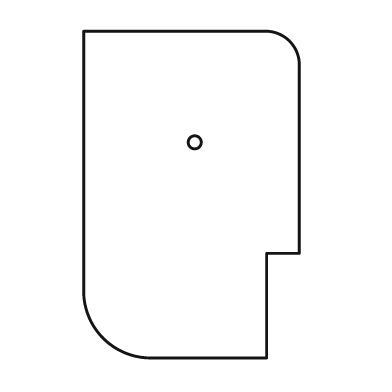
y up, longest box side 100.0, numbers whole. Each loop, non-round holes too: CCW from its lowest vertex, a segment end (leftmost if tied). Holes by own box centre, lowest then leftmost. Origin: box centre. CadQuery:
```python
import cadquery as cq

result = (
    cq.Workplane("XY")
    .moveTo(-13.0, -50.0)
    .lineTo(23.0, -50.0)
    .lineTo(23.0, -18.0)
    .lineTo(33.0, -18.0)
    .lineTo(33.0, 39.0)
    .threePointArc((30.0, 47.0), (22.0, 50.0))
    .lineTo(-33.0, 50.0)
    .lineTo(-33.0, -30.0)
    .threePointArc((-27.0, -44.0), (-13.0, -50.0))
    .close()
    .moveTo(1.0, 16.0)
    .circle(2.0)
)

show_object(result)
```